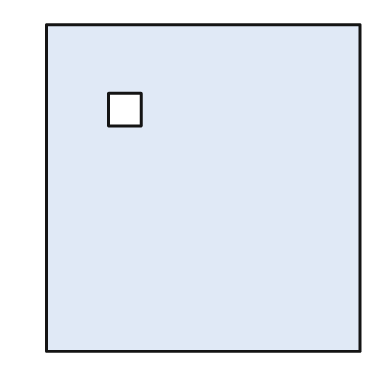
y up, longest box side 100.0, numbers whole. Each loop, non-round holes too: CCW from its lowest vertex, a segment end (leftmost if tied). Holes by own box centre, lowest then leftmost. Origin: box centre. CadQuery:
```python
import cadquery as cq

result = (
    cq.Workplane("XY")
    .moveTo(-48.0, -50.0)
    .lineTo(48.0, -50.0)
    .lineTo(48.0, 50.0)
    .lineTo(-48.0, 50.0)
    .close()
    .moveTo(-29.0, 19.0)
    .lineTo(-19.0, 19.0)
    .lineTo(-19.0, 29.0)
    .lineTo(-29.0, 29.0)
    .close()
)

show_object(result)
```